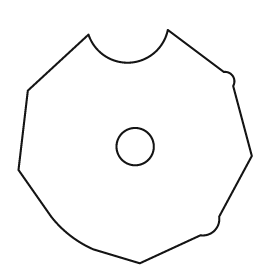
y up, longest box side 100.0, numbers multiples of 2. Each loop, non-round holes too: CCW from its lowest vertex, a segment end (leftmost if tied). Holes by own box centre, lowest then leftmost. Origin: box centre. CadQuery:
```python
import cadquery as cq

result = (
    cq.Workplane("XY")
    .moveTo(2.0, -50.0)
    .lineTo(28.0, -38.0)
    .threePointArc((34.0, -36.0), (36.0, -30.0))
    .lineTo(50.0, -4.0)
    .lineTo(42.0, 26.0)
    .threePointArc((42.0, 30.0), (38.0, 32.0))
    .lineTo(14.0, 50.0)
    .threePointArc((-2.0, 36.0), (-20.0, 48.0))
    .lineTo(-46.0, 24.0)
    .lineTo(-50.0, -10.0)
    .lineTo(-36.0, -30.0)
    .threePointArc((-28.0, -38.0), (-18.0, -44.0))
    .close()
    .moveTo(0.0, 0.0)
    .circle(8.0)
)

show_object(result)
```